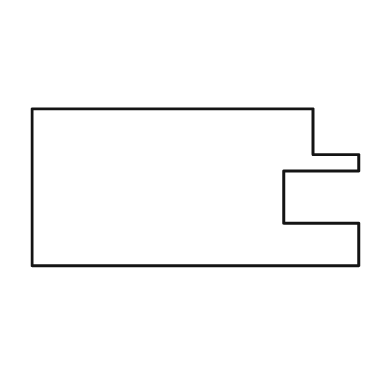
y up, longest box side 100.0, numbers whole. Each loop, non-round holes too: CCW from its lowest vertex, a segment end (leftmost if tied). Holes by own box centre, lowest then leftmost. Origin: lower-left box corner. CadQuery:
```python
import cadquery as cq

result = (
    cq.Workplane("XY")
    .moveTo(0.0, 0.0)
    .lineTo(100.0, 0.0)
    .lineTo(100.0, 13.0)
    .lineTo(77.0, 13.0)
    .lineTo(77.0, 29.0)
    .lineTo(100.0, 29.0)
    .lineTo(100.0, 34.0)
    .lineTo(86.0, 34.0)
    .lineTo(86.0, 48.0)
    .lineTo(0.0, 48.0)
    .close()
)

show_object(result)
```